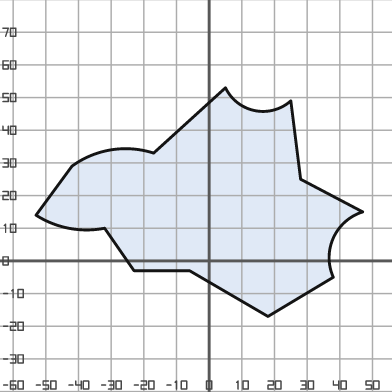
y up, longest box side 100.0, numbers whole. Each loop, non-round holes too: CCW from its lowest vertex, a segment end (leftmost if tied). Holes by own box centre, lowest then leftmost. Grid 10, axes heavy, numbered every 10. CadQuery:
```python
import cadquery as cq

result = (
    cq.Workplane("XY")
    .moveTo(18.0, -17.0)
    .lineTo(38.0, -5.0)
    .threePointArc((38.0, 7.0), (47.0, 15.0))
    .lineTo(28.0, 25.0)
    .lineTo(25.0, 49.0)
    .threePointArc((14.0, 46.0), (5.0, 53.0))
    .lineTo(-17.0, 33.0)
    .threePointArc((-30.0, 34.0), (-42.0, 29.0))
    .lineTo(-53.0, 14.0)
    .threePointArc((-43.0, 10.0), (-32.0, 10.0))
    .lineTo(-23.0, -3.0)
    .lineTo(-6.0, -3.0)
    .close()
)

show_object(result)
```